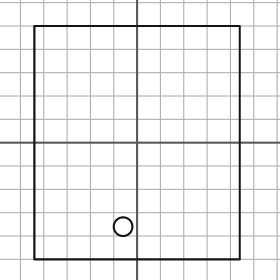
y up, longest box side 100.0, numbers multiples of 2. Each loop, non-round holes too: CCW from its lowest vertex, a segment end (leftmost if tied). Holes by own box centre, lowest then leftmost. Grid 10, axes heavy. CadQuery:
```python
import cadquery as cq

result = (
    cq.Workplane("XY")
    .moveTo(-44.0, -50.0)
    .lineTo(44.0, -50.0)
    .lineTo(44.0, 50.0)
    .lineTo(-44.0, 50.0)
    .close()
    .moveTo(-6.0, -36.0)
    .circle(4.0)
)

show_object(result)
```